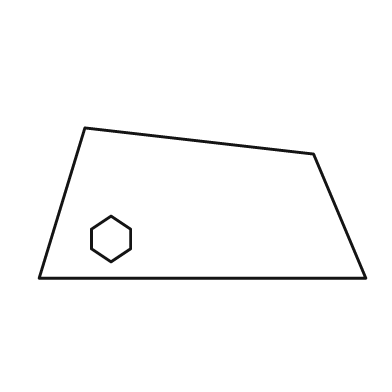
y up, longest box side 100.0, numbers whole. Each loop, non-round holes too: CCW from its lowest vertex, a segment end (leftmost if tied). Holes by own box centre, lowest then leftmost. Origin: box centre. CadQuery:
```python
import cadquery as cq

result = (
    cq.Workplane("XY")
    .moveTo(-50.0, -23.0)
    .lineTo(50.0, -23.0)
    .lineTo(34.0, 15.0)
    .lineTo(-36.0, 23.0)
    .close()
    .moveTo(-28.0, -18.0)
    .lineTo(-22.0, -14.0)
    .lineTo(-22.0, -8.0)
    .lineTo(-28.0, -4.0)
    .lineTo(-34.0, -8.0)
    .lineTo(-34.0, -14.0)
    .close()
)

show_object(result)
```